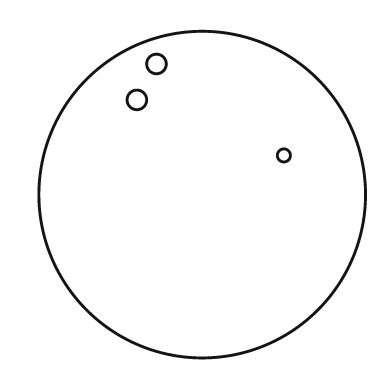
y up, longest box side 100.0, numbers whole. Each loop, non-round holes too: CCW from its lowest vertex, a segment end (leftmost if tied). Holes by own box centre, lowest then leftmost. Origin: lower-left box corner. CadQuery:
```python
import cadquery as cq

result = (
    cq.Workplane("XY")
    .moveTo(50.0, 50.0)
    .circle(50.0)
    .moveTo(75.0, 62.0)
    .circle(2.0)
    .moveTo(30.0, 79.0)
    .circle(3.0)
    .moveTo(36.0, 90.0)
    .circle(3.0)
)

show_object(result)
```